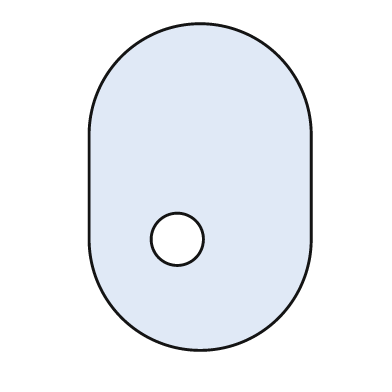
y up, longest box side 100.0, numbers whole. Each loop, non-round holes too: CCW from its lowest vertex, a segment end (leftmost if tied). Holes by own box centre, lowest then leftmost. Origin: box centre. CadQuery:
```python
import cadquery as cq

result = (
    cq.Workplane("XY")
    .moveTo(-34.0, -16.0)
    .threePointArc((0.0, -50.0), (34.0, -16.0))
    .lineTo(34.0, 16.0)
    .threePointArc((0.0, 50.0), (-34.0, 16.0))
    .close()
    .moveTo(-7.0, -16.0)
    .circle(8.0)
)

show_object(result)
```